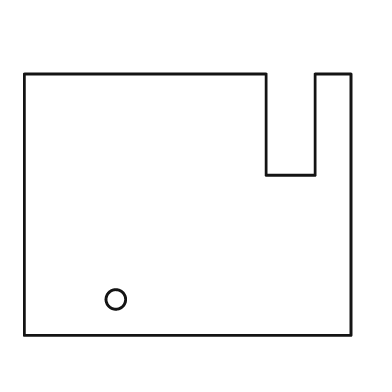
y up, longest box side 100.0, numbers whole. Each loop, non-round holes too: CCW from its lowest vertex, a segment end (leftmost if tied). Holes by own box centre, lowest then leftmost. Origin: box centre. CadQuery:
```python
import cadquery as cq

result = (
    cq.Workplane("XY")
    .moveTo(-50.0, -40.0)
    .lineTo(50.0, -40.0)
    .lineTo(50.0, 40.0)
    .lineTo(39.0, 40.0)
    .lineTo(39.0, 9.0)
    .lineTo(24.0, 9.0)
    .lineTo(24.0, 40.0)
    .lineTo(-50.0, 40.0)
    .close()
    .moveTo(-22.0, -29.0)
    .circle(3.0)
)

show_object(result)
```